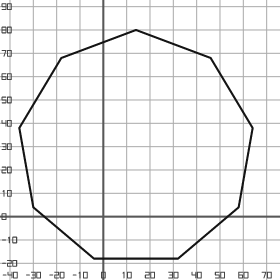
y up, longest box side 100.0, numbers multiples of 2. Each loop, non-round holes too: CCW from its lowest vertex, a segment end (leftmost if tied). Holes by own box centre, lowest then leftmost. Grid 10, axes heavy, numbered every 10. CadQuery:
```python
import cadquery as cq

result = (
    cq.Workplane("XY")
    .moveTo(-4.0, -18.0)
    .lineTo(32.0, -18.0)
    .lineTo(58.0, 4.0)
    .lineTo(64.0, 38.0)
    .lineTo(46.0, 68.0)
    .lineTo(14.0, 80.0)
    .lineTo(-18.0, 68.0)
    .lineTo(-36.0, 38.0)
    .lineTo(-30.0, 4.0)
    .close()
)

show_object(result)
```